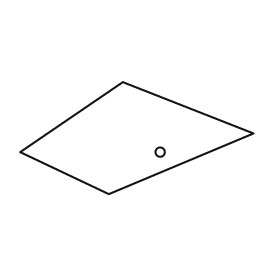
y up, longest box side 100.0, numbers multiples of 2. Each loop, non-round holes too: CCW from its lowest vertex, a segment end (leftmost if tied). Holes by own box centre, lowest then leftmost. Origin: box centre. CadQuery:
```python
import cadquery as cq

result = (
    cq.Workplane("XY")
    .moveTo(-12.0, -24.0)
    .lineTo(50.0, 2.0)
    .lineTo(-6.0, 24.0)
    .lineTo(-50.0, -6.0)
    .close()
    .moveTo(10.0, -6.0)
    .circle(2.0)
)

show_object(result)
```